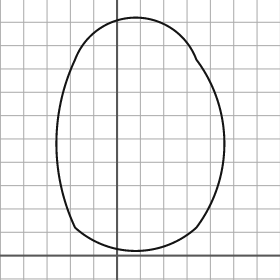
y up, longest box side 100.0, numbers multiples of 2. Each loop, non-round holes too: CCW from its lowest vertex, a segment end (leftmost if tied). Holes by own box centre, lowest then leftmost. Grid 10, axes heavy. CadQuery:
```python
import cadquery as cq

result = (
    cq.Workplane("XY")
    .moveTo(-18.0, 12.0)
    .threePointArc((8.0, 2.0), (34.0, 12.0))
    .threePointArc((46.0, 48.0), (34.0, 84.0))
    .threePointArc((8.0, 102.0), (-18.0, 84.0))
    .threePointArc((-26.0, 48.0), (-18.0, 12.0))
    .close()
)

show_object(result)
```